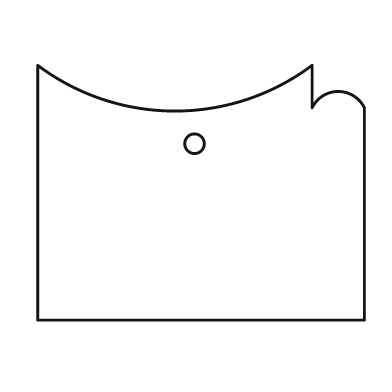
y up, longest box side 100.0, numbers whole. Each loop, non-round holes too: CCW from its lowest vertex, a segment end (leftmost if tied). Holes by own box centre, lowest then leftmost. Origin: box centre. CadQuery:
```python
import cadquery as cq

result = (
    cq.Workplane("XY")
    .moveTo(-50.0, -39.0)
    .lineTo(50.0, -39.0)
    .lineTo(50.0, 26.0)
    .threePointArc((42.0, 31.0), (34.0, 26.0))
    .lineTo(34.0, 39.0)
    .threePointArc((-8.0, 25.0), (-50.0, 39.0))
    .close()
    .moveTo(-2.0, 15.0)
    .circle(3.0)
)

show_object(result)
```